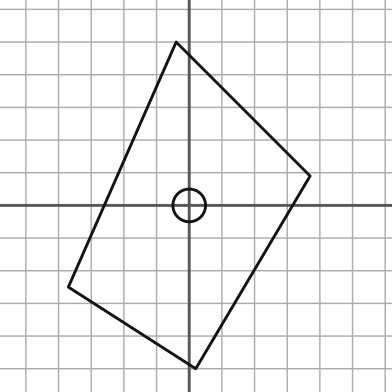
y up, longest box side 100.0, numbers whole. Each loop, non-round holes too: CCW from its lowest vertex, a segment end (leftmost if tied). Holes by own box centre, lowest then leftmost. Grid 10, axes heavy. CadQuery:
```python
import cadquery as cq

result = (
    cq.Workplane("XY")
    .moveTo(2.0, -50.0)
    .lineTo(37.0, 9.0)
    .lineTo(-4.0, 50.0)
    .lineTo(-37.0, -25.0)
    .close()
    .moveTo(0.0, 0.0)
    .circle(5.0)
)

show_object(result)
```